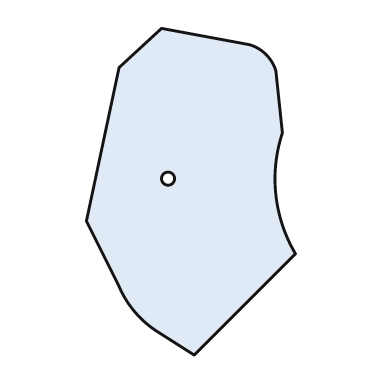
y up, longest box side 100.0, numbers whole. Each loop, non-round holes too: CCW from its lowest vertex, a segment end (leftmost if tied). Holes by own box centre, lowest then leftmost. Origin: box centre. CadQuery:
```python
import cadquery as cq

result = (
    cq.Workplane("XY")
    .moveTo(1.0, -50.0)
    .lineTo(32.0, -19.0)
    .threePointArc((26.0, -1.0), (28.0, 18.0))
    .lineTo(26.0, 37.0)
    .threePointArc((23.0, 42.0), (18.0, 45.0))
    .lineTo(-9.0, 50.0)
    .lineTo(-22.0, 38.0)
    .lineTo(-32.0, -9.0)
    .lineTo(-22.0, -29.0)
    .threePointArc((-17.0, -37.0), (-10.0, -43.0))
    .close()
    .moveTo(-7.0, 4.0)
    .circle(2.0)
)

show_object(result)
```